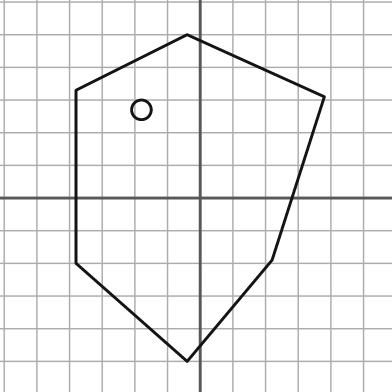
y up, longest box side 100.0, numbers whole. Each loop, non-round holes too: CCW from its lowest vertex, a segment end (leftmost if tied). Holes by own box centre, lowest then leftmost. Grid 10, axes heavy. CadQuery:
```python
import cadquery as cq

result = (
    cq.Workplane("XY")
    .moveTo(-4.0, -50.0)
    .lineTo(22.0, -19.0)
    .lineTo(38.0, 31.0)
    .lineTo(-4.0, 50.0)
    .lineTo(-38.0, 33.0)
    .lineTo(-38.0, -20.0)
    .close()
    .moveTo(-18.0, 27.0)
    .circle(3.0)
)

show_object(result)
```